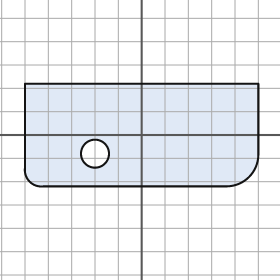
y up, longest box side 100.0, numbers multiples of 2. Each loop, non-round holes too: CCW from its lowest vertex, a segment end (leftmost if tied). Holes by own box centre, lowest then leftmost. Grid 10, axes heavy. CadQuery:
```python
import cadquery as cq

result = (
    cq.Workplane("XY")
    .moveTo(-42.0, -22.0)
    .lineTo(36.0, -22.0)
    .threePointArc((46.0, -18.0), (50.0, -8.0))
    .lineTo(50.0, 22.0)
    .lineTo(-50.0, 22.0)
    .lineTo(-50.0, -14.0)
    .threePointArc((-48.0, -20.0), (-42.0, -22.0))
    .close()
    .moveTo(-20.0, -8.0)
    .circle(6.0)
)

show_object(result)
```